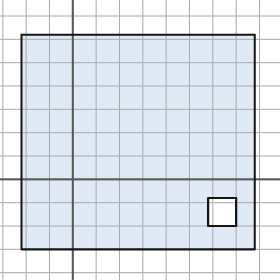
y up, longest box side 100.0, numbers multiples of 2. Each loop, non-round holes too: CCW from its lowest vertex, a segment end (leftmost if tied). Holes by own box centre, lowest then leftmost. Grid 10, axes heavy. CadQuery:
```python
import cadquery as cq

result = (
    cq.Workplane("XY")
    .moveTo(-22.0, -30.0)
    .lineTo(78.0, -30.0)
    .lineTo(78.0, 62.0)
    .lineTo(-22.0, 62.0)
    .close()
    .moveTo(58.0, -20.0)
    .lineTo(70.0, -20.0)
    .lineTo(70.0, -8.0)
    .lineTo(58.0, -8.0)
    .close()
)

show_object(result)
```